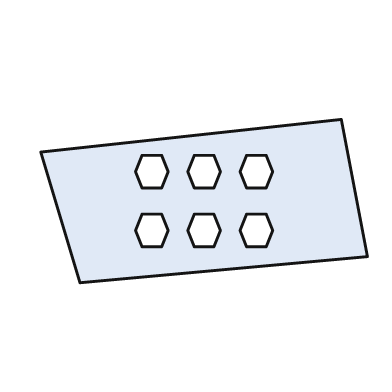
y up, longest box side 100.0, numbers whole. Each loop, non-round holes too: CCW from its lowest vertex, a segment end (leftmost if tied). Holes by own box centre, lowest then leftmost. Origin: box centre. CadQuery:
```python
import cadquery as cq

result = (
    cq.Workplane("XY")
    .moveTo(-38.0, -25.0)
    .lineTo(50.0, -17.0)
    .lineTo(42.0, 25.0)
    .lineTo(-50.0, 15.0)
    .close()
    .moveTo(-19.0, -14.0)
    .lineTo(-13.0, -14.0)
    .lineTo(-11.0, -9.0)
    .lineTo(-13.0, -4.0)
    .lineTo(-19.0, -4.0)
    .lineTo(-21.0, -9.0)
    .close()
    .moveTo(-3.0, -14.0)
    .lineTo(3.0, -14.0)
    .lineTo(5.0, -9.0)
    .lineTo(3.0, -4.0)
    .lineTo(-3.0, -4.0)
    .lineTo(-5.0, -9.0)
    .close()
    .moveTo(13.0, -14.0)
    .lineTo(19.0, -14.0)
    .lineTo(21.0, -9.0)
    .lineTo(19.0, -4.0)
    .lineTo(13.0, -4.0)
    .lineTo(11.0, -9.0)
    .close()
    .moveTo(-19.0, 4.0)
    .lineTo(-13.0, 4.0)
    .lineTo(-11.0, 9.0)
    .lineTo(-13.0, 14.0)
    .lineTo(-19.0, 14.0)
    .lineTo(-21.0, 9.0)
    .close()
    .moveTo(-3.0, 4.0)
    .lineTo(3.0, 4.0)
    .lineTo(5.0, 9.0)
    .lineTo(3.0, 14.0)
    .lineTo(-3.0, 14.0)
    .lineTo(-5.0, 9.0)
    .close()
    .moveTo(13.0, 4.0)
    .lineTo(19.0, 4.0)
    .lineTo(21.0, 9.0)
    .lineTo(19.0, 14.0)
    .lineTo(13.0, 14.0)
    .lineTo(11.0, 9.0)
    .close()
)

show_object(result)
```